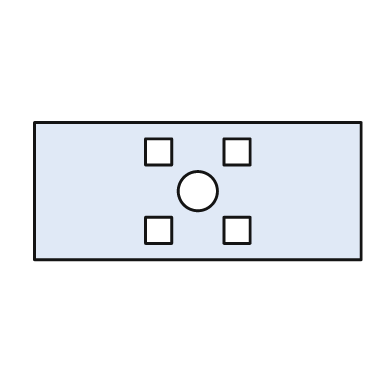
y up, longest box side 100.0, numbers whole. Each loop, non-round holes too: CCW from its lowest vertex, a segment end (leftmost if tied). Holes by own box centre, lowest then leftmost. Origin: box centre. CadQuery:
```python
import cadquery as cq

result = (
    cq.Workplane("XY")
    .moveTo(-50.0, -21.0)
    .lineTo(50.0, -21.0)
    .lineTo(50.0, 21.0)
    .lineTo(-50.0, 21.0)
    .close()
    .moveTo(-16.0, -16.0)
    .lineTo(-8.0, -16.0)
    .lineTo(-8.0, -8.0)
    .lineTo(-16.0, -8.0)
    .close()
    .moveTo(8.0, -16.0)
    .lineTo(16.0, -16.0)
    .lineTo(16.0, -8.0)
    .lineTo(8.0, -8.0)
    .close()
    .moveTo(0.0, 0.0)
    .circle(6.0)
    .moveTo(-16.0, 8.0)
    .lineTo(-8.0, 8.0)
    .lineTo(-8.0, 16.0)
    .lineTo(-16.0, 16.0)
    .close()
    .moveTo(8.0, 8.0)
    .lineTo(16.0, 8.0)
    .lineTo(16.0, 16.0)
    .lineTo(8.0, 16.0)
    .close()
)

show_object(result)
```